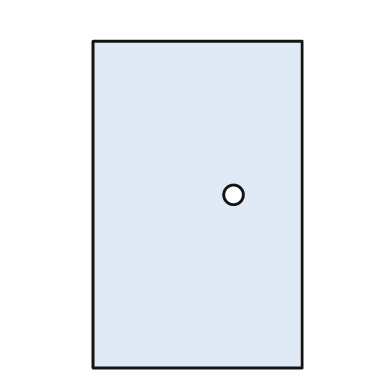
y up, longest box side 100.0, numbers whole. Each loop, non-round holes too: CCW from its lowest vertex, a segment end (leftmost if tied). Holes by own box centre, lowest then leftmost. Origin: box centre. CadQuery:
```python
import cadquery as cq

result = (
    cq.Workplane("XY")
    .moveTo(-32.0, -50.0)
    .lineTo(32.0, -50.0)
    .lineTo(32.0, 50.0)
    .lineTo(-32.0, 50.0)
    .close()
    .moveTo(11.0, 3.0)
    .circle(3.0)
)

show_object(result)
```